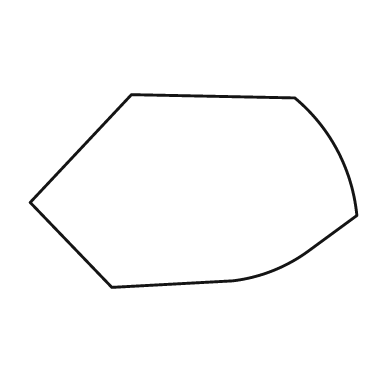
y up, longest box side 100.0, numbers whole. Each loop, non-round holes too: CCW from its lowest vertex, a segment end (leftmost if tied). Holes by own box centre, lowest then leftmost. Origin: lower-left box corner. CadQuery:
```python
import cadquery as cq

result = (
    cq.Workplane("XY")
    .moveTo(25.0, 0.0)
    .lineTo(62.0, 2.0)
    .threePointArc((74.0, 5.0), (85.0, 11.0))
    .lineTo(100.0, 22.0)
    .threePointArc((94.0, 42.0), (81.0, 58.0))
    .lineTo(31.0, 59.0)
    .lineTo(0.0, 26.0)
    .close()
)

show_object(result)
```